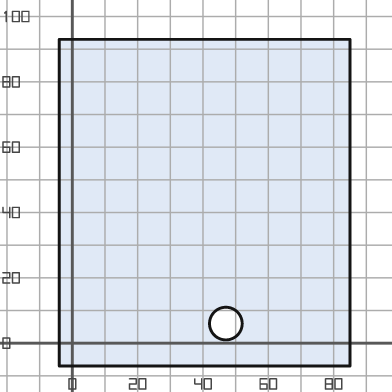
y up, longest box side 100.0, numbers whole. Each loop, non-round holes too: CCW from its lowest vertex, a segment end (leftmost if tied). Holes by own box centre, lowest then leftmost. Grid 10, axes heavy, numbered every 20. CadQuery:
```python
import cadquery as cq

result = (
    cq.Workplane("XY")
    .moveTo(-4.0, -7.0)
    .lineTo(85.0, -7.0)
    .lineTo(85.0, 93.0)
    .lineTo(-4.0, 93.0)
    .close()
    .moveTo(47.0, 6.0)
    .circle(5.0)
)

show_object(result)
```